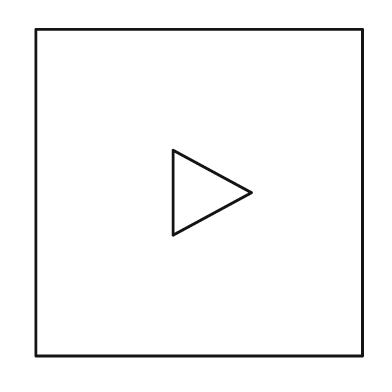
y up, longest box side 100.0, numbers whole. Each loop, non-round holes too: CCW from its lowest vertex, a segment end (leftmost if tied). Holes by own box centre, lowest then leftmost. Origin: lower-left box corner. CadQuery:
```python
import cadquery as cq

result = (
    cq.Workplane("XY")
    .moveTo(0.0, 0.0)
    .lineTo(100.0, 0.0)
    .lineTo(100.0, 100.0)
    .lineTo(0.0, 100.0)
    .close()
    .moveTo(42.0, 37.0)
    .lineTo(66.0, 50.0)
    .lineTo(42.0, 63.0)
    .close()
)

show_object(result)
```